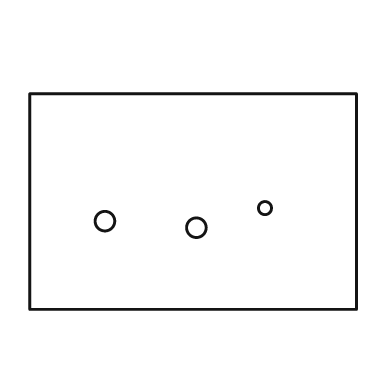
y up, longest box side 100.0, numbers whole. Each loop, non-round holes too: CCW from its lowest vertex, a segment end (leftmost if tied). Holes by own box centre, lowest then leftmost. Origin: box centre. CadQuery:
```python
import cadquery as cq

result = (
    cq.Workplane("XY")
    .moveTo(-50.0, -33.0)
    .lineTo(50.0, -33.0)
    .lineTo(50.0, 33.0)
    .lineTo(-50.0, 33.0)
    .close()
    .moveTo(1.0, -8.0)
    .circle(3.0)
    .moveTo(-27.0, -6.0)
    .circle(3.0)
    .moveTo(22.0, -2.0)
    .circle(2.0)
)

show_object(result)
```